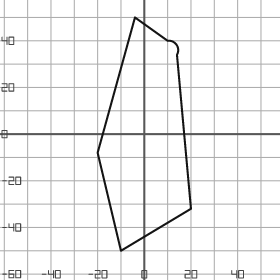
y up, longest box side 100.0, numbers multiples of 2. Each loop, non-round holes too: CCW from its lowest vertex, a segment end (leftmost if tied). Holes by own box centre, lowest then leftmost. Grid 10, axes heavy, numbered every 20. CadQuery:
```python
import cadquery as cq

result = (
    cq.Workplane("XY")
    .moveTo(-10.0, -50.0)
    .lineTo(20.0, -32.0)
    .lineTo(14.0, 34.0)
    .threePointArc((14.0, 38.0), (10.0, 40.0))
    .lineTo(-4.0, 50.0)
    .lineTo(-20.0, -8.0)
    .close()
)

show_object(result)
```